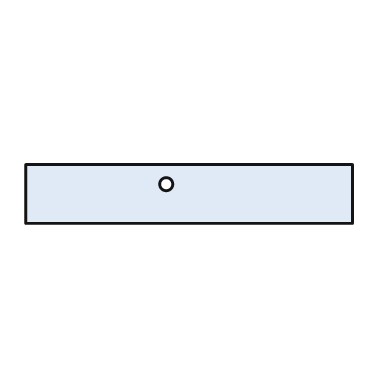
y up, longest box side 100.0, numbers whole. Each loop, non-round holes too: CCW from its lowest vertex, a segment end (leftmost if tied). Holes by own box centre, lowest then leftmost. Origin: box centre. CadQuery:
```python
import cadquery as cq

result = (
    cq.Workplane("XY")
    .moveTo(-50.0, -9.0)
    .lineTo(50.0, -9.0)
    .lineTo(50.0, 9.0)
    .lineTo(-50.0, 9.0)
    .close()
    .moveTo(-7.0, 3.0)
    .circle(2.0)
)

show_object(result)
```